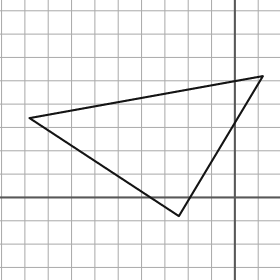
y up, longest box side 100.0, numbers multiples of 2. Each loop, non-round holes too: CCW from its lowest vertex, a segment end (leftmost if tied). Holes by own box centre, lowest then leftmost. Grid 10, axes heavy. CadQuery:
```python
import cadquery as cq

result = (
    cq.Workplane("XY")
    .moveTo(-24.0, -8.0)
    .lineTo(12.0, 52.0)
    .lineTo(-88.0, 34.0)
    .close()
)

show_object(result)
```